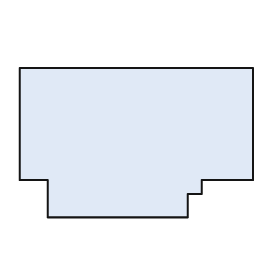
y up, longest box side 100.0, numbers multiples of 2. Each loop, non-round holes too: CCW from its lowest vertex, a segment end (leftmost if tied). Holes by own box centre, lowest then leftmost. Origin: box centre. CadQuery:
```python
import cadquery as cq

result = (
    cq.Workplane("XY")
    .moveTo(-38.0, -32.0)
    .lineTo(22.0, -32.0)
    .lineTo(22.0, -22.0)
    .lineTo(28.0, -22.0)
    .lineTo(28.0, -16.0)
    .lineTo(50.0, -16.0)
    .lineTo(50.0, 32.0)
    .lineTo(-50.0, 32.0)
    .lineTo(-50.0, -16.0)
    .lineTo(-38.0, -16.0)
    .close()
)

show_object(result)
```